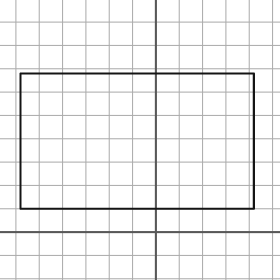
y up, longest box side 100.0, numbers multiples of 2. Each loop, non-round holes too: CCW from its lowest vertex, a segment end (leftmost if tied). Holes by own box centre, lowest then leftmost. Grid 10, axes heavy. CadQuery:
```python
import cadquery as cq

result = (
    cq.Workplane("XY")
    .moveTo(-58.0, 10.0)
    .lineTo(42.0, 10.0)
    .lineTo(42.0, 68.0)
    .lineTo(-58.0, 68.0)
    .close()
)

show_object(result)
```